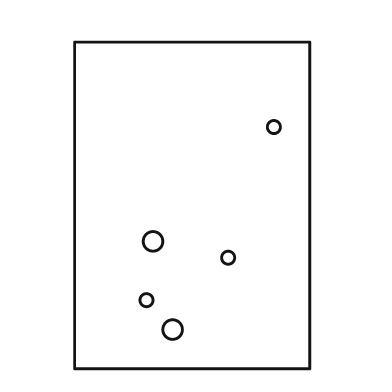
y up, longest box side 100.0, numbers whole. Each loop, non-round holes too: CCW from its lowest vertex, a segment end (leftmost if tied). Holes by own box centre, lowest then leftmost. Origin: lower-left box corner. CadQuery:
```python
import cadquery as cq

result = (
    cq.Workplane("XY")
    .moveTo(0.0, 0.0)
    .lineTo(72.0, 0.0)
    .lineTo(72.0, 100.0)
    .lineTo(0.0, 100.0)
    .close()
    .moveTo(30.0, 12.0)
    .circle(3.0)
    .moveTo(22.0, 21.0)
    .circle(2.0)
    .moveTo(47.0, 34.0)
    .circle(2.0)
    .moveTo(24.0, 39.0)
    .circle(3.0)
    .moveTo(61.0, 74.0)
    .circle(2.0)
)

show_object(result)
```